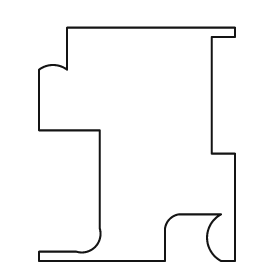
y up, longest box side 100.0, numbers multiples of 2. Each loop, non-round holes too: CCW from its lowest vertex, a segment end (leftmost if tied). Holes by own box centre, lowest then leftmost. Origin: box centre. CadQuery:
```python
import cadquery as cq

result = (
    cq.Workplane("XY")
    .moveTo(-42.0, -50.0)
    .lineTo(12.0, -50.0)
    .lineTo(12.0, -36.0)
    .threePointArc((14.0, -32.0), (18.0, -30.0))
    .lineTo(36.0, -30.0)
    .threePointArc((30.0, -40.0), (36.0, -50.0))
    .lineTo(42.0, -50.0)
    .lineTo(42.0, -4.0)
    .lineTo(32.0, -4.0)
    .lineTo(32.0, 46.0)
    .lineTo(42.0, 46.0)
    .lineTo(42.0, 50.0)
    .lineTo(-30.0, 50.0)
    .lineTo(-30.0, 32.0)
    .threePointArc((-36.0, 34.0), (-42.0, 32.0))
    .lineTo(-42.0, 6.0)
    .lineTo(-16.0, 6.0)
    .lineTo(-16.0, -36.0)
    .threePointArc((-18.0, -44.0), (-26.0, -46.0))
    .lineTo(-42.0, -46.0)
    .close()
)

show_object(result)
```